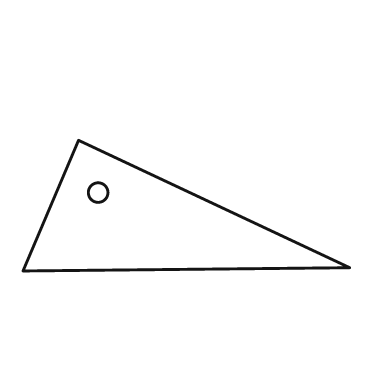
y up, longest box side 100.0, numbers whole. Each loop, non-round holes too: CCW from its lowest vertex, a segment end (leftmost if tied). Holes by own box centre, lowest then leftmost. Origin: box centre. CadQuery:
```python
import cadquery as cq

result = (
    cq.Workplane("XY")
    .moveTo(-50.0, -20.0)
    .lineTo(50.0, -19.0)
    .lineTo(-33.0, 20.0)
    .close()
    .moveTo(-27.0, 4.0)
    .circle(3.0)
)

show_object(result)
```